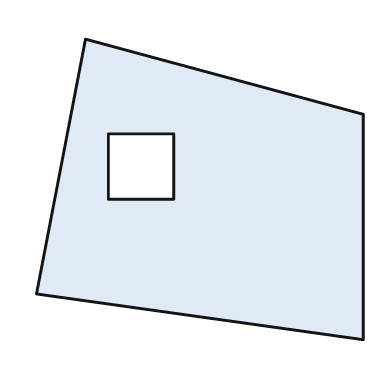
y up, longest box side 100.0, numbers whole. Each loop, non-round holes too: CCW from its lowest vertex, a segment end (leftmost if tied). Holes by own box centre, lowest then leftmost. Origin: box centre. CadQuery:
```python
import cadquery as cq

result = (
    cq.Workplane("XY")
    .moveTo(50.0, -46.0)
    .lineTo(50.0, 23.0)
    .lineTo(-35.0, 46.0)
    .lineTo(-50.0, -32.0)
    .close()
    .moveTo(-28.0, -3.0)
    .lineTo(-8.0, -3.0)
    .lineTo(-8.0, 17.0)
    .lineTo(-28.0, 17.0)
    .close()
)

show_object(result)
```